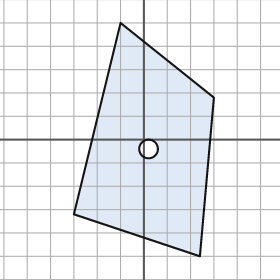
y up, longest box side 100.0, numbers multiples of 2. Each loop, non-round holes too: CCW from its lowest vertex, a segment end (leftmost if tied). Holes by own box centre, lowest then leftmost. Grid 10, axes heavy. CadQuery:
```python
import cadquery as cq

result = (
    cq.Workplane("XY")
    .moveTo(24.0, -50.0)
    .lineTo(30.0, 18.0)
    .lineTo(-10.0, 50.0)
    .lineTo(-30.0, -32.0)
    .close()
    .moveTo(2.0, -4.0)
    .circle(4.0)
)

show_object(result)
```